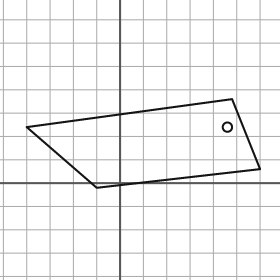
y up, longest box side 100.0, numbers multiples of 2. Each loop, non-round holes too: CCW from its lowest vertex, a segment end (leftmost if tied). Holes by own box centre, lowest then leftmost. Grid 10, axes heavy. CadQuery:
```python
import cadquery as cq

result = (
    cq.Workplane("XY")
    .moveTo(-10.0, -2.0)
    .lineTo(60.0, 6.0)
    .lineTo(48.0, 36.0)
    .lineTo(-40.0, 24.0)
    .close()
    .moveTo(46.0, 24.0)
    .circle(2.0)
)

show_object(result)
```